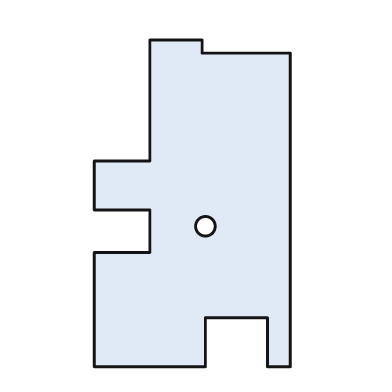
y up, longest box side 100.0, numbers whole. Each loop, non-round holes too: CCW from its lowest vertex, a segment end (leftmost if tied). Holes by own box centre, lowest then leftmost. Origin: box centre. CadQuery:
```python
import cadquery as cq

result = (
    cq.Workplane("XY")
    .moveTo(-30.0, -50.0)
    .lineTo(4.0, -50.0)
    .lineTo(4.0, -35.0)
    .lineTo(23.0, -35.0)
    .lineTo(23.0, -50.0)
    .lineTo(30.0, -50.0)
    .lineTo(30.0, 46.0)
    .lineTo(3.0, 46.0)
    .lineTo(3.0, 50.0)
    .lineTo(-13.0, 50.0)
    .lineTo(-13.0, 13.0)
    .lineTo(-30.0, 13.0)
    .lineTo(-30.0, -2.0)
    .lineTo(-13.0, -2.0)
    .lineTo(-13.0, -15.0)
    .lineTo(-30.0, -15.0)
    .close()
    .moveTo(4.0, -7.0)
    .circle(3.0)
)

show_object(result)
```